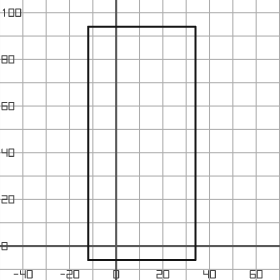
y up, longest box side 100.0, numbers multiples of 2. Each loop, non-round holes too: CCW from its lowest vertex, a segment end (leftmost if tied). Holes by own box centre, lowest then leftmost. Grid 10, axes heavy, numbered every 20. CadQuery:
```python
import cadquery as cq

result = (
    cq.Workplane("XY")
    .moveTo(-12.0, -6.0)
    .lineTo(34.0, -6.0)
    .lineTo(34.0, 94.0)
    .lineTo(-12.0, 94.0)
    .close()
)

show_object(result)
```